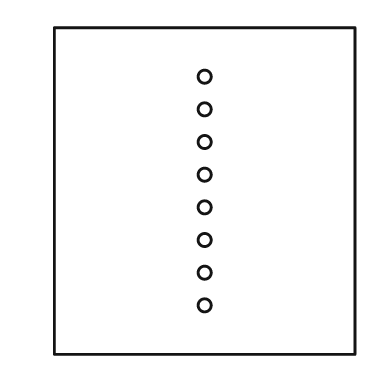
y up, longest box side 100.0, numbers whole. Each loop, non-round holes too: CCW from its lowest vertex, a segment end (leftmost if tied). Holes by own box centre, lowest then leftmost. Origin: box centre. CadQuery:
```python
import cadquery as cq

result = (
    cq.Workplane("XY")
    .moveTo(-46.0, -50.0)
    .lineTo(46.0, -50.0)
    .lineTo(46.0, 50.0)
    .lineTo(-46.0, 50.0)
    .close()
    .moveTo(0.0, -35.0)
    .circle(2.0)
    .moveTo(0.0, -25.0)
    .circle(2.0)
    .moveTo(0.0, -15.0)
    .circle(2.0)
    .moveTo(0.0, -5.0)
    .circle(2.0)
    .moveTo(0.0, 5.0)
    .circle(2.0)
    .moveTo(0.0, 15.0)
    .circle(2.0)
    .moveTo(0.0, 25.0)
    .circle(2.0)
    .moveTo(0.0, 35.0)
    .circle(2.0)
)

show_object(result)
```